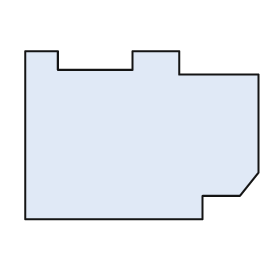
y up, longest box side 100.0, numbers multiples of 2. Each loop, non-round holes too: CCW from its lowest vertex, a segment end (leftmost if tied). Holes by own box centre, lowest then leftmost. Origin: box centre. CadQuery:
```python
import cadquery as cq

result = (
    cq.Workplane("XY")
    .moveTo(-50.0, -36.0)
    .lineTo(26.0, -36.0)
    .lineTo(26.0, -26.0)
    .lineTo(42.0, -26.0)
    .lineTo(50.0, -16.0)
    .lineTo(50.0, 26.0)
    .lineTo(16.0, 26.0)
    .lineTo(16.0, 36.0)
    .lineTo(-4.0, 36.0)
    .lineTo(-4.0, 28.0)
    .lineTo(-36.0, 28.0)
    .lineTo(-36.0, 36.0)
    .lineTo(-50.0, 36.0)
    .close()
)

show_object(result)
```